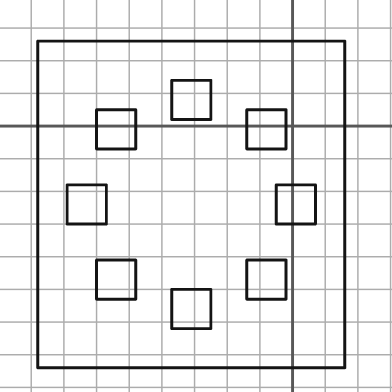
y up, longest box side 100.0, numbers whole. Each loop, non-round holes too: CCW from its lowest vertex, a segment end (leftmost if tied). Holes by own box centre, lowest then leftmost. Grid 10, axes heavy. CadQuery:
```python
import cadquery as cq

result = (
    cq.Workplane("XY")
    .moveTo(-78.0, -74.0)
    .lineTo(16.0, -74.0)
    .lineTo(16.0, 26.0)
    .lineTo(-78.0, 26.0)
    .close()
    .moveTo(-37.0, -62.0)
    .lineTo(-25.0, -62.0)
    .lineTo(-25.0, -50.0)
    .lineTo(-37.0, -50.0)
    .close()
    .moveTo(-60.0, -53.0)
    .lineTo(-48.0, -53.0)
    .lineTo(-48.0, -41.0)
    .lineTo(-60.0, -41.0)
    .close()
    .moveTo(-14.0, -53.0)
    .lineTo(-2.0, -53.0)
    .lineTo(-2.0, -41.0)
    .lineTo(-14.0, -41.0)
    .close()
    .moveTo(-69.0, -30.0)
    .lineTo(-57.0, -30.0)
    .lineTo(-57.0, -18.0)
    .lineTo(-69.0, -18.0)
    .close()
    .moveTo(-5.0, -30.0)
    .lineTo(7.0, -30.0)
    .lineTo(7.0, -18.0)
    .lineTo(-5.0, -18.0)
    .close()
    .moveTo(-60.0, -7.0)
    .lineTo(-48.0, -7.0)
    .lineTo(-48.0, 5.0)
    .lineTo(-60.0, 5.0)
    .close()
    .moveTo(-14.0, -7.0)
    .lineTo(-2.0, -7.0)
    .lineTo(-2.0, 5.0)
    .lineTo(-14.0, 5.0)
    .close()
    .moveTo(-37.0, 2.0)
    .lineTo(-25.0, 2.0)
    .lineTo(-25.0, 14.0)
    .lineTo(-37.0, 14.0)
    .close()
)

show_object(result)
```